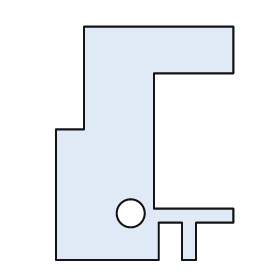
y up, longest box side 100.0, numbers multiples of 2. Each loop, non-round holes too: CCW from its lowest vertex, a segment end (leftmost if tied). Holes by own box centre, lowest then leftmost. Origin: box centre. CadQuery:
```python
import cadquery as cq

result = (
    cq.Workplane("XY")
    .moveTo(-38.0, -50.0)
    .lineTo(6.0, -50.0)
    .lineTo(6.0, -34.0)
    .lineTo(16.0, -34.0)
    .lineTo(16.0, -50.0)
    .lineTo(22.0, -50.0)
    .lineTo(22.0, -34.0)
    .lineTo(38.0, -34.0)
    .lineTo(38.0, -28.0)
    .lineTo(4.0, -28.0)
    .lineTo(4.0, 30.0)
    .lineTo(38.0, 30.0)
    .lineTo(38.0, 50.0)
    .lineTo(-26.0, 50.0)
    .lineTo(-26.0, 6.0)
    .lineTo(-38.0, 6.0)
    .close()
    .moveTo(-6.0, -30.0)
    .circle(6.0)
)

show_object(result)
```